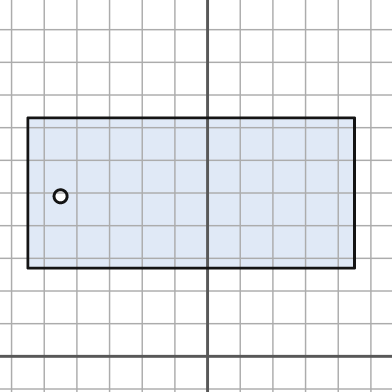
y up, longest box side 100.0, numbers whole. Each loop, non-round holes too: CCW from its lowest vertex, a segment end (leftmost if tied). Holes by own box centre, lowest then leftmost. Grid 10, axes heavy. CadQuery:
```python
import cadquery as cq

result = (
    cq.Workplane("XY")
    .moveTo(-55.0, 27.0)
    .lineTo(45.0, 27.0)
    .lineTo(45.0, 73.0)
    .lineTo(-55.0, 73.0)
    .close()
    .moveTo(-45.0, 49.0)
    .circle(2.0)
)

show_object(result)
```